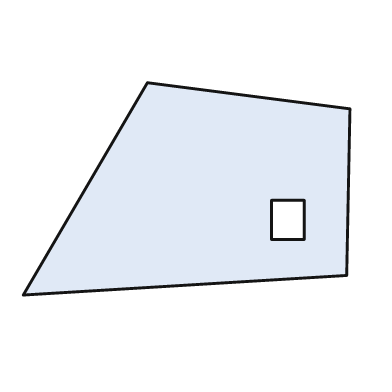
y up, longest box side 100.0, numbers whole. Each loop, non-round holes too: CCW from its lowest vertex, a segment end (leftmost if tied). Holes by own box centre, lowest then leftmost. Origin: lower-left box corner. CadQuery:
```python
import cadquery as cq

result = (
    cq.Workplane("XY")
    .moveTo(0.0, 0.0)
    .lineTo(99.0, 6.0)
    .lineTo(100.0, 57.0)
    .lineTo(38.0, 65.0)
    .close()
    .moveTo(76.0, 17.0)
    .lineTo(86.0, 17.0)
    .lineTo(86.0, 29.0)
    .lineTo(76.0, 29.0)
    .close()
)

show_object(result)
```